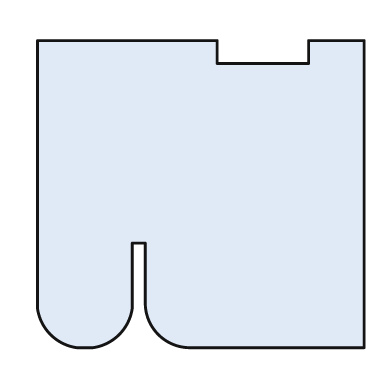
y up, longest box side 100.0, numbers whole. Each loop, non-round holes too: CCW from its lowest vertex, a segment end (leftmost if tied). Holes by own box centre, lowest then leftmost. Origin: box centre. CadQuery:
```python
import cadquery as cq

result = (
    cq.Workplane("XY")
    .moveTo(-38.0, -47.0)
    .lineTo(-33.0, -47.0)
    .threePointArc((-25.0, -43.0), (-21.0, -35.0))
    .lineTo(-21.0, -15.0)
    .lineTo(-17.0, -15.0)
    .lineTo(-17.0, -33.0)
    .threePointArc((-13.0, -43.0), (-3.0, -47.0))
    .lineTo(50.0, -47.0)
    .lineTo(50.0, 47.0)
    .lineTo(33.0, 47.0)
    .lineTo(33.0, 40.0)
    .lineTo(5.0, 40.0)
    .lineTo(5.0, 47.0)
    .lineTo(-50.0, 47.0)
    .lineTo(-50.0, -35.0)
    .threePointArc((-46.0, -43.0), (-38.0, -47.0))
    .close()
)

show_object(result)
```